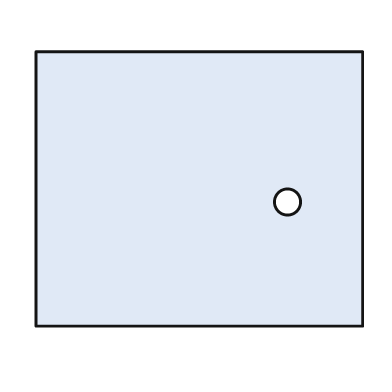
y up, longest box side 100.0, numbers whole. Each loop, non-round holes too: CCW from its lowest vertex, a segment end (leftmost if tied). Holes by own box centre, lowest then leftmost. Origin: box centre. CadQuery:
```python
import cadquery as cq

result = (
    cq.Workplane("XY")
    .moveTo(-50.0, -42.0)
    .lineTo(50.0, -42.0)
    .lineTo(50.0, 42.0)
    .lineTo(-50.0, 42.0)
    .close()
    .moveTo(27.0, -4.0)
    .circle(4.0)
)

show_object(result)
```